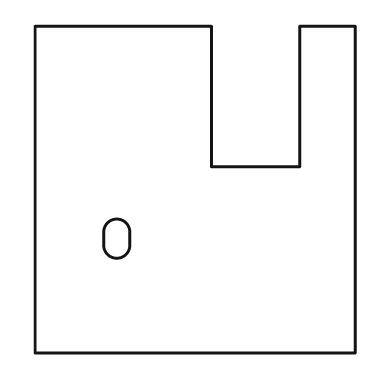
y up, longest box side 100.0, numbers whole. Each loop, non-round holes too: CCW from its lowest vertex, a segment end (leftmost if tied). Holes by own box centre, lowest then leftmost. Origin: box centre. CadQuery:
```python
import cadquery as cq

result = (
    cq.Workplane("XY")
    .moveTo(-49.0, -50.0)
    .lineTo(49.0, -50.0)
    .lineTo(49.0, 50.0)
    .lineTo(32.0, 50.0)
    .lineTo(32.0, 7.0)
    .lineTo(5.0, 7.0)
    .lineTo(5.0, 50.0)
    .lineTo(-49.0, 50.0)
    .close()
    .moveTo(-28.0, -17.0)
    .threePointArc((-24.0, -21.0), (-20.0, -17.0))
    .lineTo(-20.0, -13.0)
    .threePointArc((-24.0, -9.0), (-28.0, -13.0))
    .close()
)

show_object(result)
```